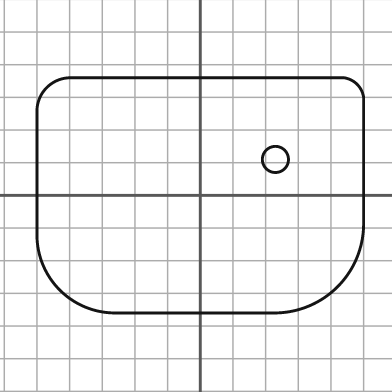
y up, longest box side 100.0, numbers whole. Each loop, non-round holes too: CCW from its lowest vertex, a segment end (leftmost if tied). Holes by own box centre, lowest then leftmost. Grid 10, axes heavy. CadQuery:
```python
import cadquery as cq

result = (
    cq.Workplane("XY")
    .moveTo(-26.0, -36.0)
    .lineTo(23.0, -36.0)
    .threePointArc((42.0, -28.0), (50.0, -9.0))
    .lineTo(50.0, 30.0)
    .threePointArc((48.0, 34.0), (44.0, 36.0))
    .lineTo(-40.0, 36.0)
    .threePointArc((-47.0, 33.0), (-50.0, 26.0))
    .lineTo(-50.0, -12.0)
    .threePointArc((-43.0, -29.0), (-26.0, -36.0))
    .close()
    .moveTo(23.0, 11.0)
    .circle(4.0)
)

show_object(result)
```